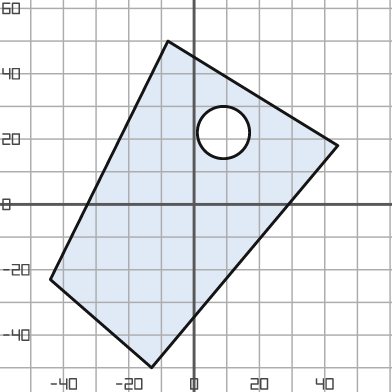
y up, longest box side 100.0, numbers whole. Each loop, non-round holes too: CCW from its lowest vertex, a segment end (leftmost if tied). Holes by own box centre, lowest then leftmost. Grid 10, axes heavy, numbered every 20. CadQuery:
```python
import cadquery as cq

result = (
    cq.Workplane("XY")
    .moveTo(-13.0, -50.0)
    .lineTo(44.0, 18.0)
    .lineTo(-8.0, 50.0)
    .lineTo(-44.0, -23.0)
    .close()
    .moveTo(9.0, 22.0)
    .circle(8.0)
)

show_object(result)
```